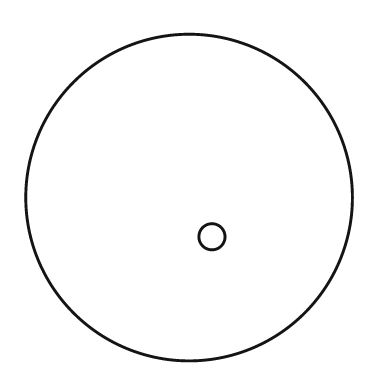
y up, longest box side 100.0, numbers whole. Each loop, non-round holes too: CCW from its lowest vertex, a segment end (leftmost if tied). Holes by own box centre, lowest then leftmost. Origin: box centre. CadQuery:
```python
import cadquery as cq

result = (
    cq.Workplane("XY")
    .moveTo(0.0, 0.0)
    .circle(50.0)
    .moveTo(7.0, -12.0)
    .circle(4.0)
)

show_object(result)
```